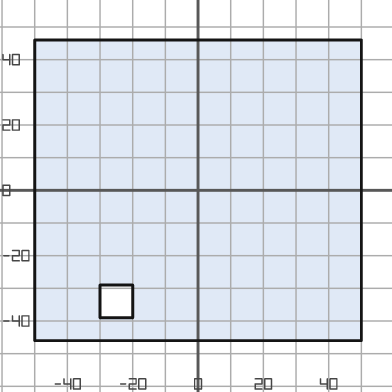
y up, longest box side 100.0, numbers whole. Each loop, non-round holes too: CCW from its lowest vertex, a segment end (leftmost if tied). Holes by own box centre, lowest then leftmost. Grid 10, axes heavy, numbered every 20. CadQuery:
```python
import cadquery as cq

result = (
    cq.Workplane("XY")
    .moveTo(-50.0, -46.0)
    .lineTo(50.0, -46.0)
    .lineTo(50.0, 46.0)
    .lineTo(-50.0, 46.0)
    .close()
    .moveTo(-30.0, -39.0)
    .lineTo(-20.0, -39.0)
    .lineTo(-20.0, -29.0)
    .lineTo(-30.0, -29.0)
    .close()
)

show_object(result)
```